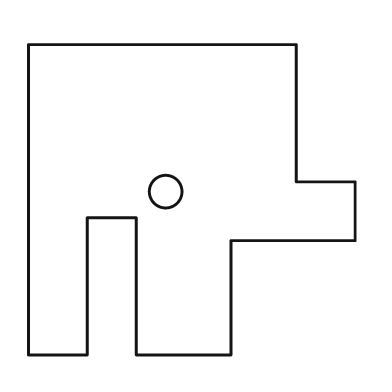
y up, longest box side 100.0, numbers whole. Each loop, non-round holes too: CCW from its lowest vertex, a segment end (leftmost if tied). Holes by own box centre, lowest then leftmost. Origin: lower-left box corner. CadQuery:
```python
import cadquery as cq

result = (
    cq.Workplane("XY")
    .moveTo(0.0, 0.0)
    .lineTo(18.0, 0.0)
    .lineTo(18.0, 42.0)
    .lineTo(33.0, 42.0)
    .lineTo(33.0, 0.0)
    .lineTo(62.0, 0.0)
    .lineTo(62.0, 35.0)
    .lineTo(100.0, 35.0)
    .lineTo(100.0, 53.0)
    .lineTo(82.0, 53.0)
    .lineTo(82.0, 95.0)
    .lineTo(0.0, 95.0)
    .close()
    .moveTo(42.0, 50.0)
    .circle(5.0)
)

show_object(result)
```